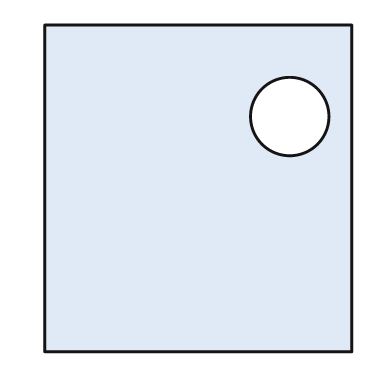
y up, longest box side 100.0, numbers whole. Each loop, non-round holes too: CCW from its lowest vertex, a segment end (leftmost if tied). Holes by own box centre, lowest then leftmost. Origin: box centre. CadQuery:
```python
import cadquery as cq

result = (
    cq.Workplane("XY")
    .moveTo(-47.0, -50.0)
    .lineTo(47.0, -50.0)
    .lineTo(47.0, 50.0)
    .lineTo(-47.0, 50.0)
    .close()
    .moveTo(28.0, 22.0)
    .circle(12.0)
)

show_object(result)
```